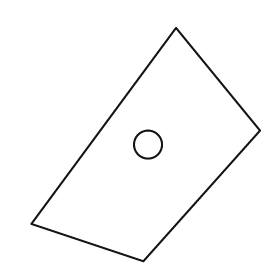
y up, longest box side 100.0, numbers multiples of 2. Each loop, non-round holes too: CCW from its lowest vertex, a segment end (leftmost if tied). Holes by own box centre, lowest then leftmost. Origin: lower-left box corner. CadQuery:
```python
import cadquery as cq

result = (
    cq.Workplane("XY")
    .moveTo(48.0, 0.0)
    .lineTo(98.0, 56.0)
    .lineTo(62.0, 100.0)
    .lineTo(0.0, 16.0)
    .close()
    .moveTo(50.0, 50.0)
    .circle(6.0)
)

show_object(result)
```